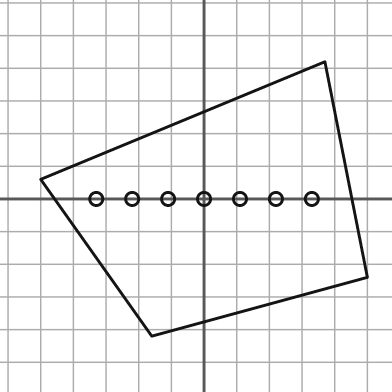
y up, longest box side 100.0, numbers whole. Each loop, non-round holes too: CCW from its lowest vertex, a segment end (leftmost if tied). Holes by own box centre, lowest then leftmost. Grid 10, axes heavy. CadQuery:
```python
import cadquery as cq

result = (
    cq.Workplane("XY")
    .moveTo(-16.0, -42.0)
    .lineTo(50.0, -24.0)
    .lineTo(37.0, 42.0)
    .lineTo(-50.0, 6.0)
    .close()
    .moveTo(-33.0, 0.0)
    .circle(2.0)
    .moveTo(-22.0, 0.0)
    .circle(2.0)
    .moveTo(-11.0, 0.0)
    .circle(2.0)
    .moveTo(0.0, 0.0)
    .circle(2.0)
    .moveTo(11.0, 0.0)
    .circle(2.0)
    .moveTo(22.0, 0.0)
    .circle(2.0)
    .moveTo(33.0, 0.0)
    .circle(2.0)
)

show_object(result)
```